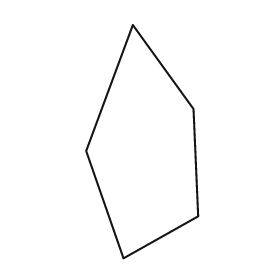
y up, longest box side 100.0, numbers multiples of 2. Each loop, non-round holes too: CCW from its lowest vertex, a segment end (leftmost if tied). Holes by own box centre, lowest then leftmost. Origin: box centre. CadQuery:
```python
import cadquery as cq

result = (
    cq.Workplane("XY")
    .moveTo(-8.0, -50.0)
    .lineTo(24.0, -32.0)
    .lineTo(22.0, 14.0)
    .lineTo(-4.0, 50.0)
    .lineTo(-24.0, -4.0)
    .close()
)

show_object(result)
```